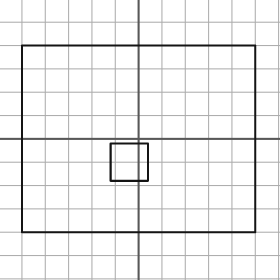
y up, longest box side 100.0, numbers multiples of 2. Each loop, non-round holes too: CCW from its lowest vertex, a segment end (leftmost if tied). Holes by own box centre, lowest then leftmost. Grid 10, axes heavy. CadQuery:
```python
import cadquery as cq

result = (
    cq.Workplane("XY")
    .moveTo(-50.0, -40.0)
    .lineTo(50.0, -40.0)
    .lineTo(50.0, 40.0)
    .lineTo(-50.0, 40.0)
    .close()
    .moveTo(-12.0, -18.0)
    .lineTo(4.0, -18.0)
    .lineTo(4.0, -2.0)
    .lineTo(-12.0, -2.0)
    .close()
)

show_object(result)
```